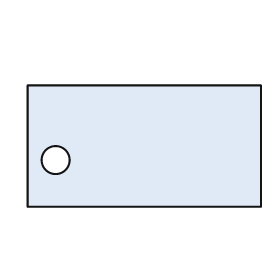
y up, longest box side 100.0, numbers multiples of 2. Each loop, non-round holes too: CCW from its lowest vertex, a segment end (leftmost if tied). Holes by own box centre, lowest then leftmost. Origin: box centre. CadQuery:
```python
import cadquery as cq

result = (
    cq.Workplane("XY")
    .moveTo(-50.0, -26.0)
    .lineTo(50.0, -26.0)
    .lineTo(50.0, 26.0)
    .lineTo(-50.0, 26.0)
    .close()
    .moveTo(-38.0, -6.0)
    .circle(6.0)
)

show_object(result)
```